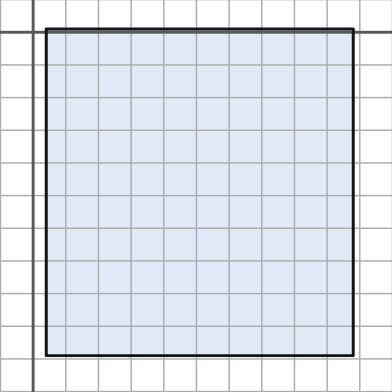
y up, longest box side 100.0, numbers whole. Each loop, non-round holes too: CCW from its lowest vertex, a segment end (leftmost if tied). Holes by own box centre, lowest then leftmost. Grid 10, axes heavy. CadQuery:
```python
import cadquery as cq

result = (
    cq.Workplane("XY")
    .moveTo(4.0, -99.0)
    .lineTo(98.0, -99.0)
    .lineTo(98.0, 1.0)
    .lineTo(4.0, 1.0)
    .close()
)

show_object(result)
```